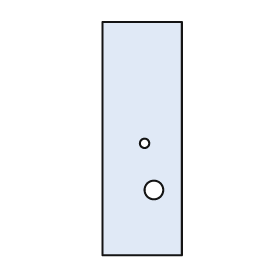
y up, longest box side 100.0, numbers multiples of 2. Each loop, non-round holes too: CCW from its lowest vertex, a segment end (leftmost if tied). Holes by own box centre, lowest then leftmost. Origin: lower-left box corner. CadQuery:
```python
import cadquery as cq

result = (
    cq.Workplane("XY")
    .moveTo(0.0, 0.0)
    .lineTo(34.0, 0.0)
    .lineTo(34.0, 100.0)
    .lineTo(0.0, 100.0)
    .close()
    .moveTo(22.0, 28.0)
    .circle(4.0)
    .moveTo(18.0, 48.0)
    .circle(2.0)
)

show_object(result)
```